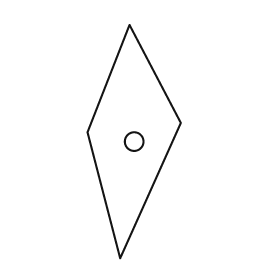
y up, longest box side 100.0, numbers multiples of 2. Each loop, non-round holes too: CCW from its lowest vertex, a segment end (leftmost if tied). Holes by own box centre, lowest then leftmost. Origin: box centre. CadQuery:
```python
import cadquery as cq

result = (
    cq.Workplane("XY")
    .moveTo(-6.0, -50.0)
    .lineTo(20.0, 8.0)
    .lineTo(-2.0, 50.0)
    .lineTo(-20.0, 4.0)
    .close()
    .moveTo(0.0, 0.0)
    .circle(4.0)
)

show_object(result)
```